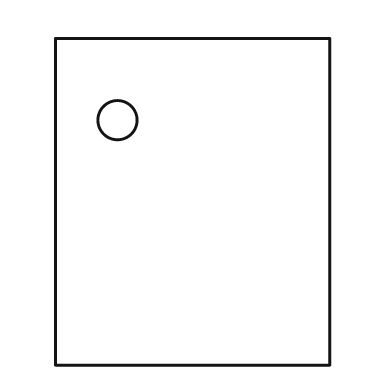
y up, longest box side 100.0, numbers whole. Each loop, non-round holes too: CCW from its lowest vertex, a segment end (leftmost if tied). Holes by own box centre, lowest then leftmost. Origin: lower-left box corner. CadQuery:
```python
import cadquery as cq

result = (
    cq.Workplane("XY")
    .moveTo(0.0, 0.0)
    .lineTo(84.0, 0.0)
    .lineTo(84.0, 100.0)
    .lineTo(0.0, 100.0)
    .close()
    .moveTo(19.0, 75.0)
    .circle(6.0)
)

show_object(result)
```